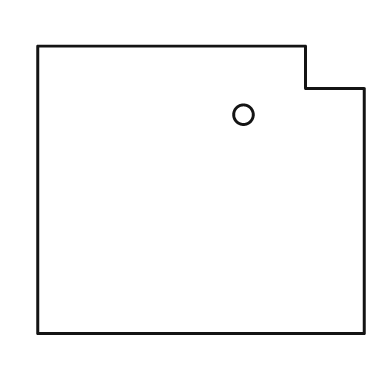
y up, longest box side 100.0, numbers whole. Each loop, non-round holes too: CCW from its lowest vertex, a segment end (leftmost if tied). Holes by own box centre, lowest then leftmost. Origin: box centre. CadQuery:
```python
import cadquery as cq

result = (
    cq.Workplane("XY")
    .moveTo(-50.0, -44.0)
    .lineTo(50.0, -44.0)
    .lineTo(50.0, 31.0)
    .lineTo(32.0, 31.0)
    .lineTo(32.0, 44.0)
    .lineTo(-50.0, 44.0)
    .close()
    .moveTo(13.0, 23.0)
    .circle(3.0)
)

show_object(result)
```